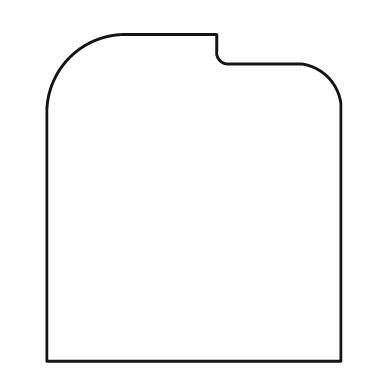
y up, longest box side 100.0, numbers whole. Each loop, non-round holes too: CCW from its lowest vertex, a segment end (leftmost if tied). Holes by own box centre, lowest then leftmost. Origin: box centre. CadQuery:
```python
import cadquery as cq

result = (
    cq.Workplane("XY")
    .moveTo(-45.0, -50.0)
    .lineTo(45.0, -50.0)
    .lineTo(45.0, 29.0)
    .threePointArc((41.0, 37.0), (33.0, 41.0))
    .lineTo(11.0, 41.0)
    .threePointArc((8.0, 42.0), (7.0, 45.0))
    .lineTo(7.0, 50.0)
    .lineTo(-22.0, 50.0)
    .threePointArc((-38.0, 43.0), (-45.0, 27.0))
    .close()
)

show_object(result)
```